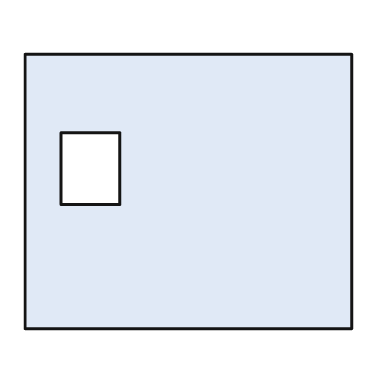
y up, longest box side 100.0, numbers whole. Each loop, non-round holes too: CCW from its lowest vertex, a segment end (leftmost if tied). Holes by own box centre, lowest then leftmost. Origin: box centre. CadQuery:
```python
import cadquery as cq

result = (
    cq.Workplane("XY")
    .moveTo(-50.0, -42.0)
    .lineTo(50.0, -42.0)
    .lineTo(50.0, 42.0)
    .lineTo(-50.0, 42.0)
    .close()
    .moveTo(-39.0, -4.0)
    .lineTo(-21.0, -4.0)
    .lineTo(-21.0, 18.0)
    .lineTo(-39.0, 18.0)
    .close()
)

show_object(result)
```